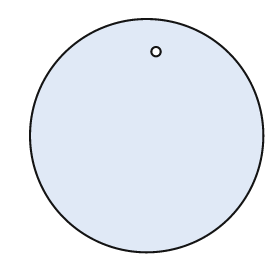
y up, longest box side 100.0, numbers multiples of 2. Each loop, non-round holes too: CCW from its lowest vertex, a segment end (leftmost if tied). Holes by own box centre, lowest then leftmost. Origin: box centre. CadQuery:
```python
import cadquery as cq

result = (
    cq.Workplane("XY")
    .moveTo(0.0, 0.0)
    .circle(50.0)
    .moveTo(4.0, 36.0)
    .circle(2.0)
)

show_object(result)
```